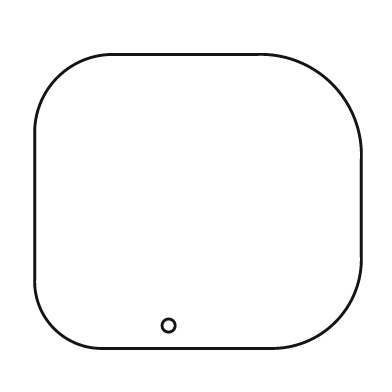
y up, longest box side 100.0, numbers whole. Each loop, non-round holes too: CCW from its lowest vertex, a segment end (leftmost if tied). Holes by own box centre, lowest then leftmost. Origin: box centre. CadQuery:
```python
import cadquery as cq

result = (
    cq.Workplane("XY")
    .moveTo(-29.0, -45.0)
    .lineTo(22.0, -45.0)
    .threePointArc((42.0, -37.0), (50.0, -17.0))
    .lineTo(50.0, 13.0)
    .threePointArc((41.0, 36.0), (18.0, 45.0))
    .lineTo(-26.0, 45.0)
    .threePointArc((-43.0, 38.0), (-50.0, 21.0))
    .lineTo(-50.0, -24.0)
    .threePointArc((-44.0, -39.0), (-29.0, -45.0))
    .close()
    .moveTo(-9.0, -38.0)
    .circle(2.0)
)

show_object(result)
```